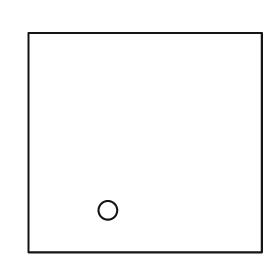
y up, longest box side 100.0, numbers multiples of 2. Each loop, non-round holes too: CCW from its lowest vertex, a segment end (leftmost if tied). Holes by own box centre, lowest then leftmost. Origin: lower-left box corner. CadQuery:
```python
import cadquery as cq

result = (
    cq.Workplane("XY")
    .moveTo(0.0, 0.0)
    .lineTo(100.0, 0.0)
    .lineTo(100.0, 94.0)
    .lineTo(0.0, 94.0)
    .close()
    .moveTo(34.0, 18.0)
    .circle(4.0)
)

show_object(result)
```